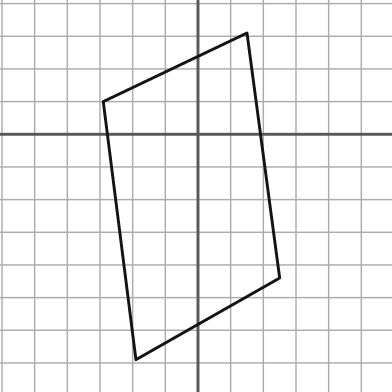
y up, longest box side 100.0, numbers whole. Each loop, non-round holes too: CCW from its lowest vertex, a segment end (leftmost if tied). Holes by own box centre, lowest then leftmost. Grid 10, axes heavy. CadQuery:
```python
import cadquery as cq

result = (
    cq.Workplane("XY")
    .moveTo(-19.0, -69.0)
    .lineTo(25.0, -44.0)
    .lineTo(15.0, 31.0)
    .lineTo(-29.0, 10.0)
    .close()
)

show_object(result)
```